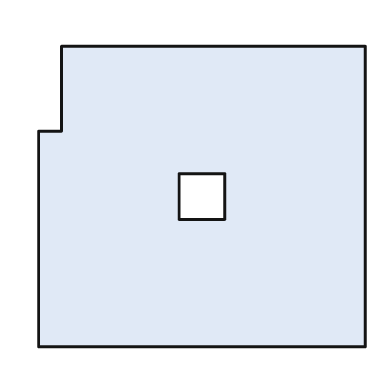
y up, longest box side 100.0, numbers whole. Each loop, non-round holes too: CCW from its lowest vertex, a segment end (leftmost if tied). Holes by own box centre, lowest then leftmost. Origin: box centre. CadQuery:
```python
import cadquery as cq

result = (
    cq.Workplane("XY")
    .moveTo(-50.0, -46.0)
    .lineTo(50.0, -46.0)
    .lineTo(50.0, 46.0)
    .lineTo(-43.0, 46.0)
    .lineTo(-43.0, 20.0)
    .lineTo(-50.0, 20.0)
    .close()
    .moveTo(-7.0, -7.0)
    .lineTo(7.0, -7.0)
    .lineTo(7.0, 7.0)
    .lineTo(-7.0, 7.0)
    .close()
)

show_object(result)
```